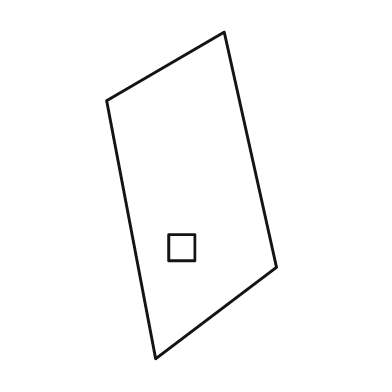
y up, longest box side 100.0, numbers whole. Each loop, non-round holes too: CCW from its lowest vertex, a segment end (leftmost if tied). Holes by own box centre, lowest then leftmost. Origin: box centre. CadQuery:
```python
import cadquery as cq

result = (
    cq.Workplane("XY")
    .moveTo(-11.0, -50.0)
    .lineTo(26.0, -22.0)
    .lineTo(10.0, 50.0)
    .lineTo(-26.0, 29.0)
    .close()
    .moveTo(-7.0, -20.0)
    .lineTo(1.0, -20.0)
    .lineTo(1.0, -12.0)
    .lineTo(-7.0, -12.0)
    .close()
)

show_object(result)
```